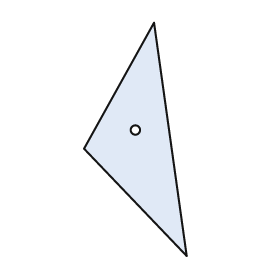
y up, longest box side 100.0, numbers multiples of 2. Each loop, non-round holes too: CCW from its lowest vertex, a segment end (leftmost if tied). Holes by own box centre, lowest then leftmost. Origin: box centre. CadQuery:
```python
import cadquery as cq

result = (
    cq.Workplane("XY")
    .moveTo(22.0, -50.0)
    .lineTo(8.0, 50.0)
    .lineTo(-22.0, -4.0)
    .close()
    .moveTo(0.0, 4.0)
    .circle(2.0)
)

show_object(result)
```